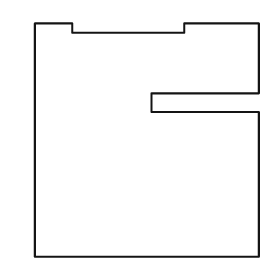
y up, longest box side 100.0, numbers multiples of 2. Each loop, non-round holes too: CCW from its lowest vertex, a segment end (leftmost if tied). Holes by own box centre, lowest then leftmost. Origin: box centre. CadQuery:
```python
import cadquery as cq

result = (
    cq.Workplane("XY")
    .moveTo(-48.0, -50.0)
    .lineTo(48.0, -50.0)
    .lineTo(48.0, 12.0)
    .lineTo(2.0, 12.0)
    .lineTo(2.0, 20.0)
    .lineTo(48.0, 20.0)
    .lineTo(48.0, 50.0)
    .lineTo(16.0, 50.0)
    .lineTo(16.0, 46.0)
    .lineTo(-32.0, 46.0)
    .lineTo(-32.0, 50.0)
    .lineTo(-48.0, 50.0)
    .close()
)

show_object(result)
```